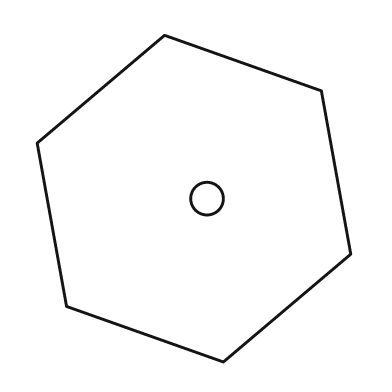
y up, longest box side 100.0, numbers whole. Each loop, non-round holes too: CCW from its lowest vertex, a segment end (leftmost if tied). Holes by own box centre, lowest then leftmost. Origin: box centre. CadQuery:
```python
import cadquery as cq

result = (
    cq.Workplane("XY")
    .moveTo(9.0, -50.0)
    .lineTo(48.0, -17.0)
    .lineTo(39.0, 33.0)
    .lineTo(-9.0, 50.0)
    .lineTo(-48.0, 17.0)
    .lineTo(-39.0, -33.0)
    .close()
    .moveTo(4.0, 0.0)
    .circle(5.0)
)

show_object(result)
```